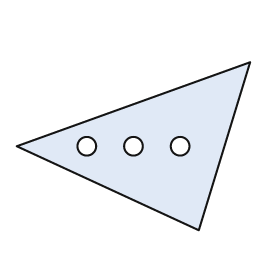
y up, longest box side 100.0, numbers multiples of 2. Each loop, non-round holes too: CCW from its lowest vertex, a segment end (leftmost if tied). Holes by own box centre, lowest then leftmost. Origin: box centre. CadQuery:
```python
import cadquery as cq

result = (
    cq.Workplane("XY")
    .moveTo(28.0, -36.0)
    .lineTo(50.0, 36.0)
    .lineTo(-50.0, 0.0)
    .close()
    .moveTo(-20.0, 0.0)
    .circle(4.0)
    .moveTo(0.0, 0.0)
    .circle(4.0)
    .moveTo(20.0, 0.0)
    .circle(4.0)
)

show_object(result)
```